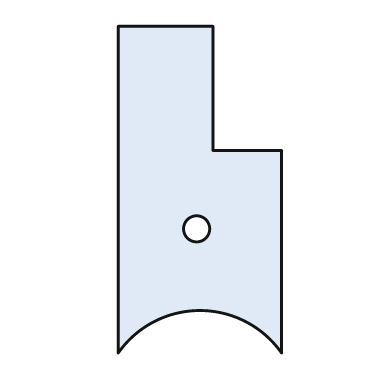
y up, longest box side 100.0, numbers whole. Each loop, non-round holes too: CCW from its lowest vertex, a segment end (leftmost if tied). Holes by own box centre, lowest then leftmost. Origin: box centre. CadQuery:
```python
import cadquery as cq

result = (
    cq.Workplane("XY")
    .moveTo(-25.0, -50.0)
    .threePointArc((0.0, -37.0), (25.0, -50.0))
    .lineTo(25.0, 12.0)
    .lineTo(4.0, 12.0)
    .lineTo(4.0, 50.0)
    .lineTo(-25.0, 50.0)
    .close()
    .moveTo(-1.0, -12.0)
    .circle(4.0)
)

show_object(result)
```